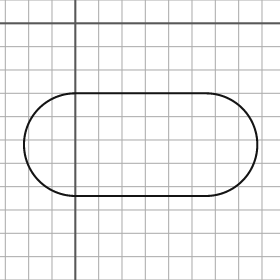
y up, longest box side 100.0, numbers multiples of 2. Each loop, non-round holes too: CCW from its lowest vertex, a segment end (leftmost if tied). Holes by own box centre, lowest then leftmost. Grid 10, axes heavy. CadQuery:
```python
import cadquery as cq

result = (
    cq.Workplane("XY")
    .moveTo(0.0, -74.0)
    .lineTo(56.0, -74.0)
    .threePointArc((78.0, -52.0), (56.0, -30.0))
    .lineTo(0.0, -30.0)
    .threePointArc((-22.0, -52.0), (0.0, -74.0))
    .close()
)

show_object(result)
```